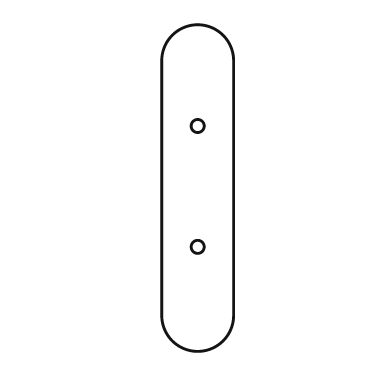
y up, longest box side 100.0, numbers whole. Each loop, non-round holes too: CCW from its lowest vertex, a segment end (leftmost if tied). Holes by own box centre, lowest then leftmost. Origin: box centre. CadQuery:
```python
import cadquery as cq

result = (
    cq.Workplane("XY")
    .moveTo(-11.0, -39.0)
    .threePointArc((0.0, -50.0), (11.0, -39.0))
    .lineTo(11.0, 39.0)
    .threePointArc((0.0, 50.0), (-11.0, 39.0))
    .close()
    .moveTo(0.0, -18.0)
    .circle(2.0)
    .moveTo(0.0, 19.0)
    .circle(2.0)
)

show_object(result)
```